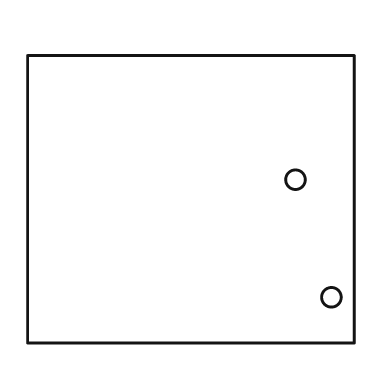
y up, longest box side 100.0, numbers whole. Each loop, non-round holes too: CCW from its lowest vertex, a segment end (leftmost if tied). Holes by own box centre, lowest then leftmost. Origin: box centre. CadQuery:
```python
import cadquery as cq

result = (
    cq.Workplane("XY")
    .moveTo(-50.0, -44.0)
    .lineTo(50.0, -44.0)
    .lineTo(50.0, 44.0)
    .lineTo(-50.0, 44.0)
    .close()
    .moveTo(43.0, -30.0)
    .circle(3.0)
    .moveTo(32.0, 6.0)
    .circle(3.0)
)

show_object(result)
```